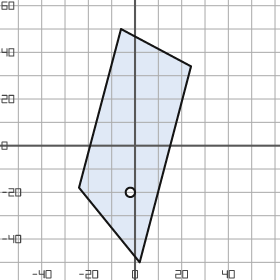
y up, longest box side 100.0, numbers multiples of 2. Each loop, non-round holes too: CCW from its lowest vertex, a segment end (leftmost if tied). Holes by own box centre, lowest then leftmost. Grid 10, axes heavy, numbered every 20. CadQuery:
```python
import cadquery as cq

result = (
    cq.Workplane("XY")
    .moveTo(2.0, -50.0)
    .lineTo(24.0, 34.0)
    .lineTo(-6.0, 50.0)
    .lineTo(-24.0, -18.0)
    .close()
    .moveTo(-2.0, -20.0)
    .circle(2.0)
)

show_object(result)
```